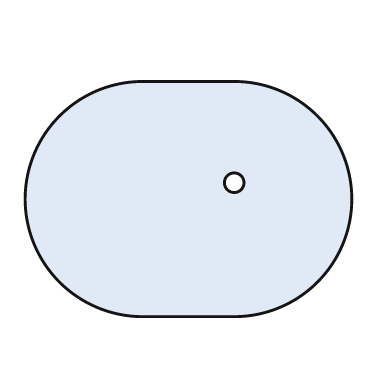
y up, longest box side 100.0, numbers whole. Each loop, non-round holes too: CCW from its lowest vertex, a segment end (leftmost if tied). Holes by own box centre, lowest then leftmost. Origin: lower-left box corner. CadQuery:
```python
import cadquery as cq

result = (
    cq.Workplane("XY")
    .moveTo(36.0, 0.0)
    .lineTo(64.0, 0.0)
    .threePointArc((100.0, 36.0), (64.0, 72.0))
    .lineTo(36.0, 72.0)
    .threePointArc((0.0, 36.0), (36.0, 0.0))
    .close()
    .moveTo(64.0, 41.0)
    .circle(3.0)
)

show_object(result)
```